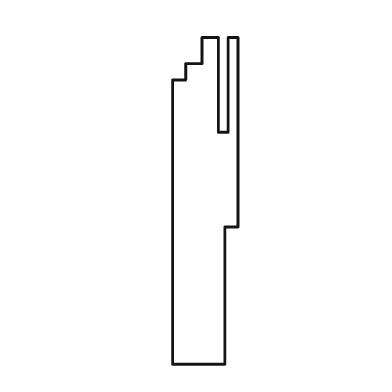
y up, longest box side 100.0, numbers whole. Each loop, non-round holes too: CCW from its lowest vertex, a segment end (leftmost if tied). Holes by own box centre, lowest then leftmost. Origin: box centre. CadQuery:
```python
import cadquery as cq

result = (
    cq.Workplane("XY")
    .moveTo(-10.0, -50.0)
    .lineTo(6.0, -50.0)
    .lineTo(6.0, -8.0)
    .lineTo(10.0, -8.0)
    .lineTo(10.0, 50.0)
    .lineTo(7.0, 50.0)
    .lineTo(7.0, 21.0)
    .lineTo(4.0, 21.0)
    .lineTo(4.0, 50.0)
    .lineTo(-1.0, 50.0)
    .lineTo(-1.0, 42.0)
    .lineTo(-6.0, 42.0)
    .lineTo(-6.0, 37.0)
    .lineTo(-10.0, 37.0)
    .close()
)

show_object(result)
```